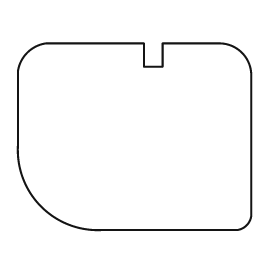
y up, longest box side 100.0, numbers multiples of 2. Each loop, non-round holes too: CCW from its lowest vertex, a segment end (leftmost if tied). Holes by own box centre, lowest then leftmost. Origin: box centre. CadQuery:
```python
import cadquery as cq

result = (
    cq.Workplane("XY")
    .moveTo(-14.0, -40.0)
    .lineTo(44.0, -40.0)
    .threePointArc((48.0, -38.0), (50.0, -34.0))
    .lineTo(50.0, 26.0)
    .threePointArc((46.0, 36.0), (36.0, 40.0))
    .lineTo(12.0, 40.0)
    .lineTo(12.0, 30.0)
    .lineTo(4.0, 30.0)
    .lineTo(4.0, 40.0)
    .lineTo(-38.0, 40.0)
    .threePointArc((-46.0, 36.0), (-50.0, 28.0))
    .lineTo(-50.0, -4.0)
    .threePointArc((-40.0, -30.0), (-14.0, -40.0))
    .close()
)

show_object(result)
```